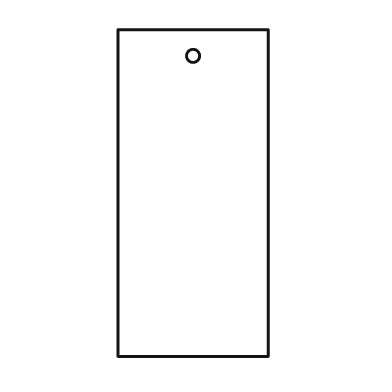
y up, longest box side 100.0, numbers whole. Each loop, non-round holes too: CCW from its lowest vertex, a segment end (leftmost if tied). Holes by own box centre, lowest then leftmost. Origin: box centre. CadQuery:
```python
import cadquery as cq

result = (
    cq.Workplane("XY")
    .moveTo(-23.0, -50.0)
    .lineTo(23.0, -50.0)
    .lineTo(23.0, 50.0)
    .lineTo(-23.0, 50.0)
    .close()
    .moveTo(0.0, 42.0)
    .circle(2.0)
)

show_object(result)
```